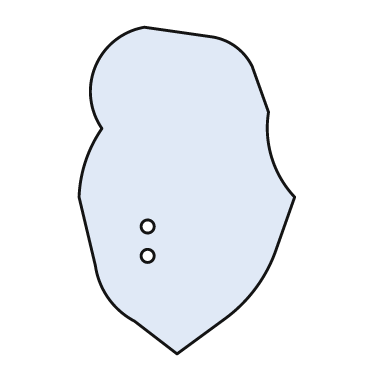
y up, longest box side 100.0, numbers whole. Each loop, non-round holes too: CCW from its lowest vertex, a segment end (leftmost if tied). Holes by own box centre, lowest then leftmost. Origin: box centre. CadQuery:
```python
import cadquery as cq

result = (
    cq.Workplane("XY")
    .moveTo(-3.0, -50.0)
    .lineTo(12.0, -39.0)
    .threePointArc((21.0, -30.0), (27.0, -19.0))
    .lineTo(33.0, -2.0)
    .threePointArc((26.0, 10.0), (25.0, 24.0))
    .lineTo(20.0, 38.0)
    .threePointArc((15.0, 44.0), (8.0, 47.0))
    .lineTo(-13.0, 50.0)
    .threePointArc((-28.0, 38.0), (-26.0, 19.0))
    .threePointArc((-31.0, 9.0), (-33.0, -2.0))
    .lineTo(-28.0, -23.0)
    .threePointArc((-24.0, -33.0), (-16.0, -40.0))
    .close()
    .moveTo(-12.0, -20.0)
    .circle(2.0)
    .moveTo(-12.0, -11.0)
    .circle(2.0)
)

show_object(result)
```